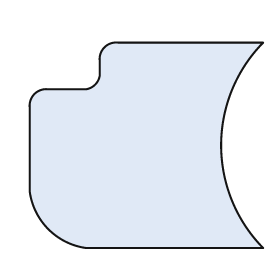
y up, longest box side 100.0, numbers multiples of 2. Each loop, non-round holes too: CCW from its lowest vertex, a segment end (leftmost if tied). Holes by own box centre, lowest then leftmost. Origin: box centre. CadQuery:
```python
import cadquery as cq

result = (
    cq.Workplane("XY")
    .moveTo(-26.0, -44.0)
    .lineTo(50.0, -44.0)
    .threePointArc((32.0, 0.0), (50.0, 44.0))
    .lineTo(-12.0, 44.0)
    .threePointArc((-18.0, 42.0), (-20.0, 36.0))
    .lineTo(-20.0, 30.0)
    .threePointArc((-22.0, 26.0), (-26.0, 24.0))
    .lineTo(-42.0, 24.0)
    .threePointArc((-48.0, 22.0), (-50.0, 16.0))
    .lineTo(-50.0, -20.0)
    .threePointArc((-42.0, -36.0), (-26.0, -44.0))
    .close()
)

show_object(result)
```